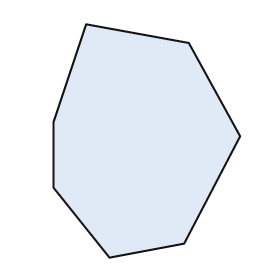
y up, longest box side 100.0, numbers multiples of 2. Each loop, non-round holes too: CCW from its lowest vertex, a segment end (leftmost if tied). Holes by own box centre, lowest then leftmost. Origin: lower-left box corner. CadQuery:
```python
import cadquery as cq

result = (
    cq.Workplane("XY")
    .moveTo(24.0, 0.0)
    .lineTo(56.0, 6.0)
    .lineTo(80.0, 52.0)
    .lineTo(58.0, 92.0)
    .lineTo(14.0, 100.0)
    .lineTo(0.0, 58.0)
    .lineTo(0.0, 30.0)
    .close()
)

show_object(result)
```